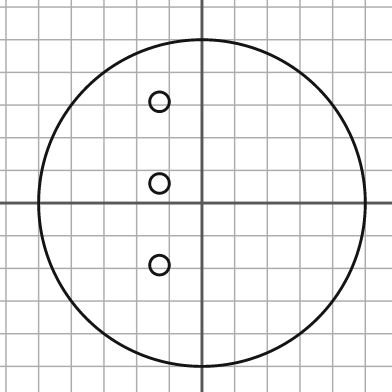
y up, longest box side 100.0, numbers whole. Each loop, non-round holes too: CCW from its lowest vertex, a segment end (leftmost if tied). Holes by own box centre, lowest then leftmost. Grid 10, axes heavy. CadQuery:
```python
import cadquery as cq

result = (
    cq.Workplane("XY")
    .moveTo(0.0, 0.0)
    .circle(50.0)
    .moveTo(-13.0, -19.0)
    .circle(3.0)
    .moveTo(-13.0, 6.0)
    .circle(3.0)
    .moveTo(-13.0, 31.0)
    .circle(3.0)
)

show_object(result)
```